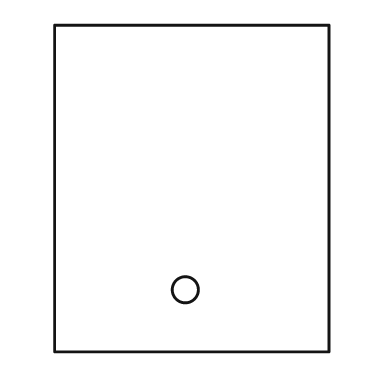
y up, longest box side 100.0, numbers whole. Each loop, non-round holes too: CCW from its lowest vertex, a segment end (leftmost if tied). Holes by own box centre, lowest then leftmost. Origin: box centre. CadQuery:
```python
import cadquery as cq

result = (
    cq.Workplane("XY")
    .moveTo(-42.0, -50.0)
    .lineTo(42.0, -50.0)
    .lineTo(42.0, 50.0)
    .lineTo(-42.0, 50.0)
    .close()
    .moveTo(-2.0, -31.0)
    .circle(4.0)
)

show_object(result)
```